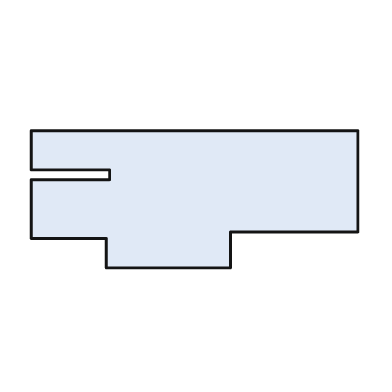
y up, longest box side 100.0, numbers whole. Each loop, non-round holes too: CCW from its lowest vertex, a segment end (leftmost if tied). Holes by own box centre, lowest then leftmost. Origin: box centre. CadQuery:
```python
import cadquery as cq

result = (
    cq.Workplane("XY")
    .moveTo(-27.0, -21.0)
    .lineTo(11.0, -21.0)
    .lineTo(11.0, -10.0)
    .lineTo(50.0, -10.0)
    .lineTo(50.0, 21.0)
    .lineTo(-50.0, 21.0)
    .lineTo(-50.0, 9.0)
    .lineTo(-26.0, 9.0)
    .lineTo(-26.0, 6.0)
    .lineTo(-50.0, 6.0)
    .lineTo(-50.0, -12.0)
    .lineTo(-27.0, -12.0)
    .close()
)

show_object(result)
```